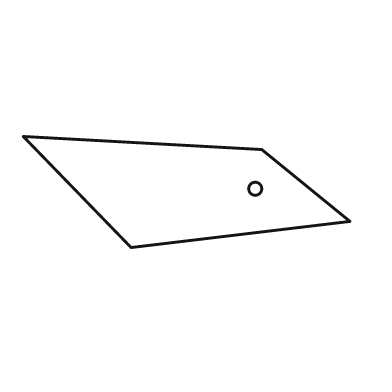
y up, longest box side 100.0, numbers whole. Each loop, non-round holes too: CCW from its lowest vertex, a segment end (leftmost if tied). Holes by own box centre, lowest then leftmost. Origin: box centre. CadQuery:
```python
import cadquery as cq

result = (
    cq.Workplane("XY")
    .moveTo(-17.0, -17.0)
    .lineTo(50.0, -9.0)
    .lineTo(23.0, 13.0)
    .lineTo(-50.0, 17.0)
    .close()
    .moveTo(21.0, 1.0)
    .circle(2.0)
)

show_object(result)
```